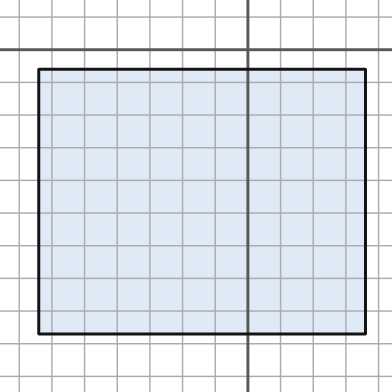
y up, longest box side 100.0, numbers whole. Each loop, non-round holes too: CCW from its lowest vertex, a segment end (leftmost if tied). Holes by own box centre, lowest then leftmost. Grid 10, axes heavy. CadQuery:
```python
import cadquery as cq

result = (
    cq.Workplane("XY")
    .moveTo(-64.0, -87.0)
    .lineTo(36.0, -87.0)
    .lineTo(36.0, -6.0)
    .lineTo(-64.0, -6.0)
    .close()
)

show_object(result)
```